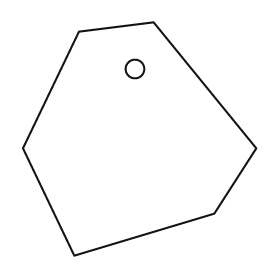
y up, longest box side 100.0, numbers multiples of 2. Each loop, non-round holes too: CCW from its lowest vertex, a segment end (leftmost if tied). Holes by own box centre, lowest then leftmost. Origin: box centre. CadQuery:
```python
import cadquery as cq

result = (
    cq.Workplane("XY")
    .moveTo(-28.0, -50.0)
    .lineTo(32.0, -32.0)
    .lineTo(50.0, -4.0)
    .lineTo(6.0, 50.0)
    .lineTo(-26.0, 46.0)
    .lineTo(-50.0, -4.0)
    .close()
    .moveTo(-2.0, 30.0)
    .circle(4.0)
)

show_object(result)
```